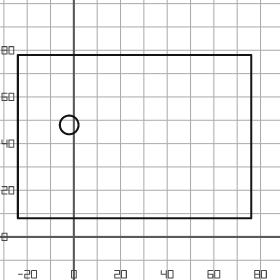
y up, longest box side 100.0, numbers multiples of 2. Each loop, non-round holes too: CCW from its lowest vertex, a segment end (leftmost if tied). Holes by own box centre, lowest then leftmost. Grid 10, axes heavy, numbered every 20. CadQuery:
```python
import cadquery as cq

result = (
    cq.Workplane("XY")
    .moveTo(-24.0, 8.0)
    .lineTo(76.0, 8.0)
    .lineTo(76.0, 78.0)
    .lineTo(-24.0, 78.0)
    .close()
    .moveTo(-2.0, 48.0)
    .circle(4.0)
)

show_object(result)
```